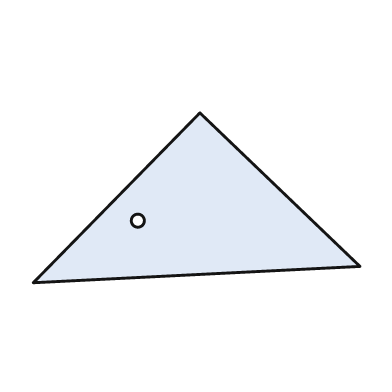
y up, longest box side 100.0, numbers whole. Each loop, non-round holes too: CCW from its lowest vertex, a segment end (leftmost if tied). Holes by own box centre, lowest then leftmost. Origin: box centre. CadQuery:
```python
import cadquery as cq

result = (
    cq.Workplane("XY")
    .moveTo(-50.0, -26.0)
    .lineTo(50.0, -21.0)
    .lineTo(1.0, 26.0)
    .close()
    .moveTo(-18.0, -7.0)
    .circle(2.0)
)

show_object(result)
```